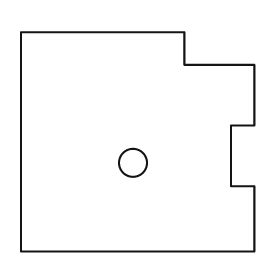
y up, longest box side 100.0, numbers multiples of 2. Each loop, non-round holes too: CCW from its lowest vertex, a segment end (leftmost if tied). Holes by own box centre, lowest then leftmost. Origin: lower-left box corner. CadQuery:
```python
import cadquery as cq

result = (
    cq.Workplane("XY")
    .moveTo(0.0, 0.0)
    .lineTo(100.0, 0.0)
    .lineTo(100.0, 28.0)
    .lineTo(90.0, 28.0)
    .lineTo(90.0, 54.0)
    .lineTo(100.0, 54.0)
    .lineTo(100.0, 80.0)
    .lineTo(70.0, 80.0)
    .lineTo(70.0, 94.0)
    .lineTo(0.0, 94.0)
    .close()
    .moveTo(48.0, 38.0)
    .circle(6.0)
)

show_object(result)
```